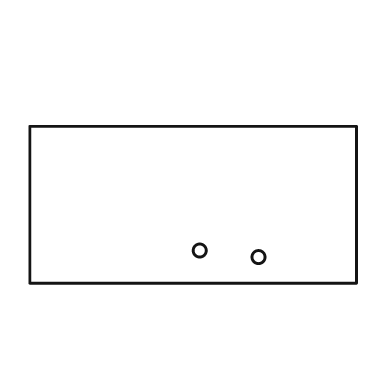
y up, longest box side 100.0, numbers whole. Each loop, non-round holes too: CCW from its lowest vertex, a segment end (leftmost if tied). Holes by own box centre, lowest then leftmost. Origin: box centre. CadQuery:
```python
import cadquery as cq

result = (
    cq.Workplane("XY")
    .moveTo(-50.0, -24.0)
    .lineTo(50.0, -24.0)
    .lineTo(50.0, 24.0)
    .lineTo(-50.0, 24.0)
    .close()
    .moveTo(20.0, -16.0)
    .circle(2.0)
    .moveTo(2.0, -14.0)
    .circle(2.0)
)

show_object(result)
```